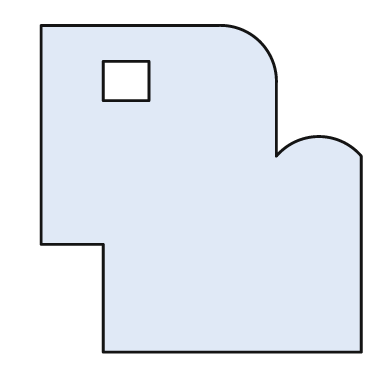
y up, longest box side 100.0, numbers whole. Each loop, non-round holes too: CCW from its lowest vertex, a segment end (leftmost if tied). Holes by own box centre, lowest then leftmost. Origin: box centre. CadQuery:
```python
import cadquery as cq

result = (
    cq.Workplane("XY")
    .moveTo(-30.0, -50.0)
    .lineTo(49.0, -50.0)
    .lineTo(49.0, 10.0)
    .threePointArc((36.0, 16.0), (23.0, 10.0))
    .lineTo(23.0, 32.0)
    .threePointArc((18.0, 45.0), (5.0, 50.0))
    .lineTo(-49.0, 50.0)
    .lineTo(-49.0, -17.0)
    .lineTo(-30.0, -17.0)
    .close()
    .moveTo(-30.0, 27.0)
    .lineTo(-16.0, 27.0)
    .lineTo(-16.0, 39.0)
    .lineTo(-30.0, 39.0)
    .close()
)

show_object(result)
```